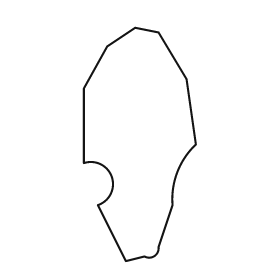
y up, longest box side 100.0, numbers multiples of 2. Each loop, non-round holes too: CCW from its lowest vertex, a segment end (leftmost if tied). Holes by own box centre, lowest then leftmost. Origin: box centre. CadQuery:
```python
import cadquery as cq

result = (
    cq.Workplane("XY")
    .moveTo(-6.0, -50.0)
    .lineTo(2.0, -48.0)
    .threePointArc((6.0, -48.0), (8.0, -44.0))
    .lineTo(14.0, -26.0)
    .threePointArc((16.0, -12.0), (24.0, 0.0))
    .lineTo(20.0, 28.0)
    .lineTo(8.0, 48.0)
    .lineTo(-2.0, 50.0)
    .lineTo(-14.0, 42.0)
    .lineTo(-24.0, 24.0)
    .lineTo(-24.0, -8.0)
    .threePointArc((-12.0, -14.0), (-18.0, -26.0))
    .close()
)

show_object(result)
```